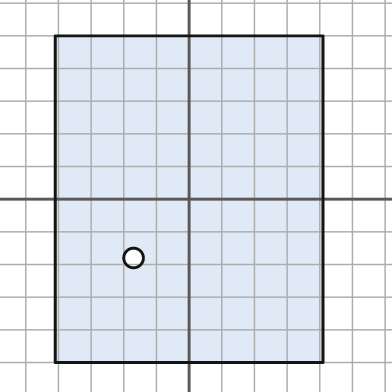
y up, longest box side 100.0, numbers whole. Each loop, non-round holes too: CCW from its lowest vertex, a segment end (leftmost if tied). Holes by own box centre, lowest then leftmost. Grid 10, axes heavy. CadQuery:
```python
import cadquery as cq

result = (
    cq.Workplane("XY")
    .moveTo(-41.0, -50.0)
    .lineTo(41.0, -50.0)
    .lineTo(41.0, 50.0)
    .lineTo(-41.0, 50.0)
    .close()
    .moveTo(-17.0, -18.0)
    .circle(3.0)
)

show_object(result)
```